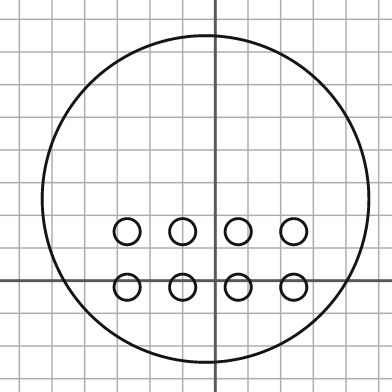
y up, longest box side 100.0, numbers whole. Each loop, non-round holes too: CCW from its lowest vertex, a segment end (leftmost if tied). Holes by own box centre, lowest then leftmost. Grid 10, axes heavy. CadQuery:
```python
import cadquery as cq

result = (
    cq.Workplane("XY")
    .moveTo(-3.0, 25.0)
    .circle(50.0)
    .moveTo(-27.0, -2.0)
    .circle(4.0)
    .moveTo(-10.0, -2.0)
    .circle(4.0)
    .moveTo(7.0, -2.0)
    .circle(4.0)
    .moveTo(24.0, -2.0)
    .circle(4.0)
    .moveTo(-27.0, 15.0)
    .circle(4.0)
    .moveTo(-10.0, 15.0)
    .circle(4.0)
    .moveTo(7.0, 15.0)
    .circle(4.0)
    .moveTo(24.0, 15.0)
    .circle(4.0)
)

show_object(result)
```